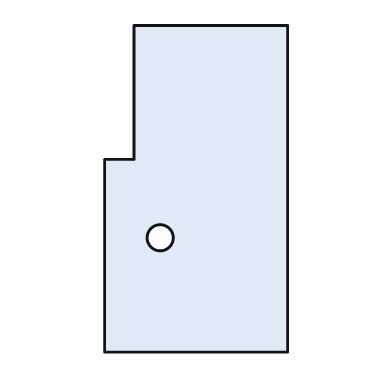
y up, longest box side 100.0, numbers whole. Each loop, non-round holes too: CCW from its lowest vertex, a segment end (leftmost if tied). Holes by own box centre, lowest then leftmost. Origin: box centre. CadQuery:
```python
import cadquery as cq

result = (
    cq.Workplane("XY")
    .moveTo(-28.0, -50.0)
    .lineTo(28.0, -50.0)
    .lineTo(28.0, 50.0)
    .lineTo(-19.0, 50.0)
    .lineTo(-19.0, 9.0)
    .lineTo(-28.0, 9.0)
    .close()
    .moveTo(-11.0, -15.0)
    .circle(4.0)
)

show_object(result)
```